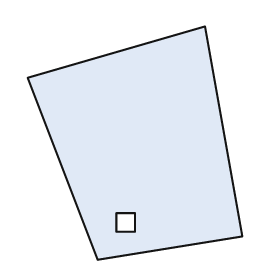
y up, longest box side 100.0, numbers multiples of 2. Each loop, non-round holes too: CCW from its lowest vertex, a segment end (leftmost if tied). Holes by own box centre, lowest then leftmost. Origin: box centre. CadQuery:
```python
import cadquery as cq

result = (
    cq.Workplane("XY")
    .moveTo(-16.0, -50.0)
    .lineTo(46.0, -40.0)
    .lineTo(30.0, 50.0)
    .lineTo(-46.0, 28.0)
    .close()
    .moveTo(-8.0, -38.0)
    .lineTo(0.0, -38.0)
    .lineTo(0.0, -30.0)
    .lineTo(-8.0, -30.0)
    .close()
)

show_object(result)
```